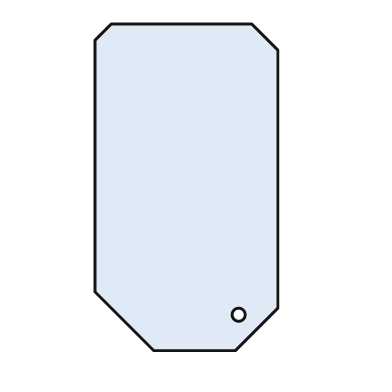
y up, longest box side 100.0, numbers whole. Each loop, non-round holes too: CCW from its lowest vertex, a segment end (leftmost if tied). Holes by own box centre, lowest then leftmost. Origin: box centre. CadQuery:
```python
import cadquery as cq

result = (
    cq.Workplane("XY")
    .moveTo(-10.0, -50.0)
    .lineTo(15.0, -50.0)
    .lineTo(28.0, -37.0)
    .lineTo(28.0, 42.0)
    .lineTo(20.0, 50.0)
    .lineTo(-23.0, 50.0)
    .lineTo(-28.0, 45.0)
    .lineTo(-28.0, -32.0)
    .close()
    .moveTo(16.0, -39.0)
    .circle(2.0)
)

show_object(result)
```